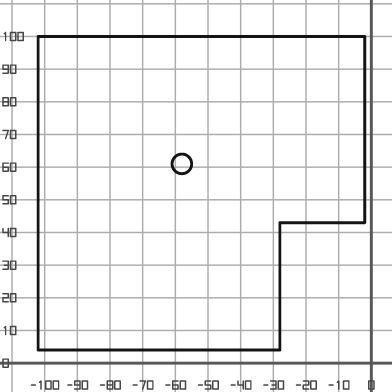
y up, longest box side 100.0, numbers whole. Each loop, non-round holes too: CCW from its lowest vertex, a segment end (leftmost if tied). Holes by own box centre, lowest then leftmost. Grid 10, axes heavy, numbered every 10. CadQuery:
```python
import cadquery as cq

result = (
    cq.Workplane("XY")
    .moveTo(-102.0, 4.0)
    .lineTo(-28.0, 4.0)
    .lineTo(-28.0, 43.0)
    .lineTo(-2.0, 43.0)
    .lineTo(-2.0, 100.0)
    .lineTo(-102.0, 100.0)
    .close()
    .moveTo(-58.0, 61.0)
    .circle(3.0)
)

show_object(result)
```